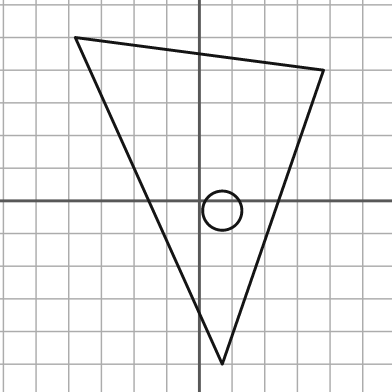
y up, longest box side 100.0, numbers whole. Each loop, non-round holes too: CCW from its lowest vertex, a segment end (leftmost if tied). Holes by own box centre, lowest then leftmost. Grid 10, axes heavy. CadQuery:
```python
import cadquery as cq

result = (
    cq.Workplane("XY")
    .moveTo(7.0, -50.0)
    .lineTo(38.0, 40.0)
    .lineTo(-38.0, 50.0)
    .close()
    .moveTo(7.0, -3.0)
    .circle(6.0)
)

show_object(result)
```